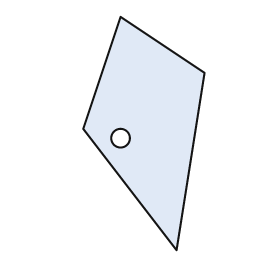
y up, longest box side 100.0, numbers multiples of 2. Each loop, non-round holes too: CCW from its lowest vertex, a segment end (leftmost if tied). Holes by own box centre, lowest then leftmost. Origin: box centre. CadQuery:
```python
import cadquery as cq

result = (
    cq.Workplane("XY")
    .moveTo(14.0, -50.0)
    .lineTo(26.0, 26.0)
    .lineTo(-10.0, 50.0)
    .lineTo(-26.0, 2.0)
    .close()
    .moveTo(-10.0, -2.0)
    .circle(4.0)
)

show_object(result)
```